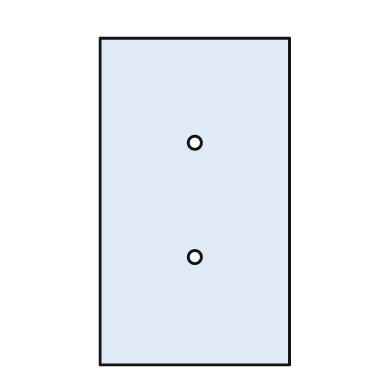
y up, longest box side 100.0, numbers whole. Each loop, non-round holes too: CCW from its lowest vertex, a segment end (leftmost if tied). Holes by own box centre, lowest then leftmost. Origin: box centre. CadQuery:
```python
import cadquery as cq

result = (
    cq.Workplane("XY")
    .moveTo(-29.0, -50.0)
    .lineTo(29.0, -50.0)
    .lineTo(29.0, 50.0)
    .lineTo(-29.0, 50.0)
    .close()
    .moveTo(0.0, -17.0)
    .circle(2.0)
    .moveTo(0.0, 18.0)
    .circle(2.0)
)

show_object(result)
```